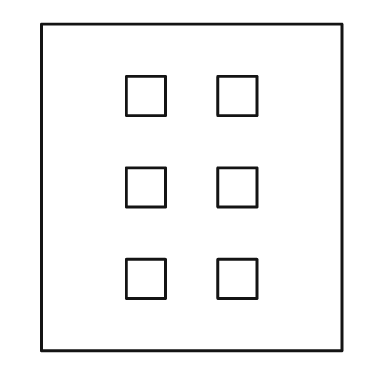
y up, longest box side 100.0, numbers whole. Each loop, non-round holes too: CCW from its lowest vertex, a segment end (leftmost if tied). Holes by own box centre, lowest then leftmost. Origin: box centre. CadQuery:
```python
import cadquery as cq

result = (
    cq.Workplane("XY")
    .moveTo(-46.0, -50.0)
    .lineTo(46.0, -50.0)
    .lineTo(46.0, 50.0)
    .lineTo(-46.0, 50.0)
    .close()
    .moveTo(-20.0, -34.0)
    .lineTo(-8.0, -34.0)
    .lineTo(-8.0, -22.0)
    .lineTo(-20.0, -22.0)
    .close()
    .moveTo(8.0, -34.0)
    .lineTo(20.0, -34.0)
    .lineTo(20.0, -22.0)
    .lineTo(8.0, -22.0)
    .close()
    .moveTo(-20.0, -6.0)
    .lineTo(-8.0, -6.0)
    .lineTo(-8.0, 6.0)
    .lineTo(-20.0, 6.0)
    .close()
    .moveTo(8.0, -6.0)
    .lineTo(20.0, -6.0)
    .lineTo(20.0, 6.0)
    .lineTo(8.0, 6.0)
    .close()
    .moveTo(-20.0, 22.0)
    .lineTo(-8.0, 22.0)
    .lineTo(-8.0, 34.0)
    .lineTo(-20.0, 34.0)
    .close()
    .moveTo(8.0, 22.0)
    .lineTo(20.0, 22.0)
    .lineTo(20.0, 34.0)
    .lineTo(8.0, 34.0)
    .close()
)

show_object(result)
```